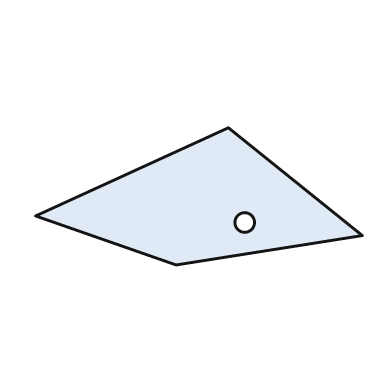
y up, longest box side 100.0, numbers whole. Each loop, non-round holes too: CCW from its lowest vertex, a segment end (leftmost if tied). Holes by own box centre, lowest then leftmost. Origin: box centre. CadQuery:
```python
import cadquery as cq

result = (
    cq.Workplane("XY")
    .moveTo(-7.0, -21.0)
    .lineTo(50.0, -12.0)
    .lineTo(9.0, 21.0)
    .lineTo(-50.0, -6.0)
    .close()
    .moveTo(14.0, -8.0)
    .circle(3.0)
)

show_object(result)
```